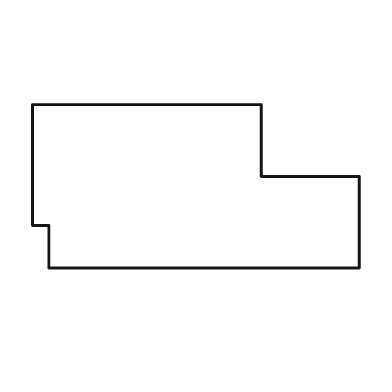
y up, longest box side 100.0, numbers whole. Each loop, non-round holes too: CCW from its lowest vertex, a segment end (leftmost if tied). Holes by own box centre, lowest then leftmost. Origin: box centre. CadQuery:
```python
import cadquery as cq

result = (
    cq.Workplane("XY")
    .moveTo(-45.0, -25.0)
    .lineTo(50.0, -25.0)
    .lineTo(50.0, 3.0)
    .lineTo(20.0, 3.0)
    .lineTo(20.0, 25.0)
    .lineTo(-50.0, 25.0)
    .lineTo(-50.0, -12.0)
    .lineTo(-45.0, -12.0)
    .close()
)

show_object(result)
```